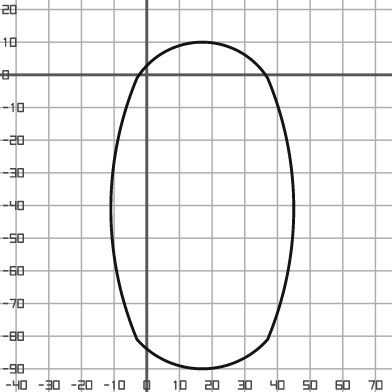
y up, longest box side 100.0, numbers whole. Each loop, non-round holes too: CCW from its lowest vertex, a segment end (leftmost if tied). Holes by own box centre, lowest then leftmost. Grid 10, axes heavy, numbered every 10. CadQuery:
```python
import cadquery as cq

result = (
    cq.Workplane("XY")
    .moveTo(-3.0, -81.0)
    .threePointArc((17.0, -90.0), (37.0, -81.0))
    .threePointArc((45.0, -41.0), (37.0, -1.0))
    .threePointArc((17.0, 10.0), (-3.0, -1.0))
    .threePointArc((-11.0, -41.0), (-3.0, -81.0))
    .close()
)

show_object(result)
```